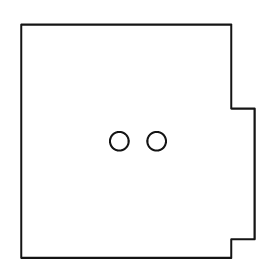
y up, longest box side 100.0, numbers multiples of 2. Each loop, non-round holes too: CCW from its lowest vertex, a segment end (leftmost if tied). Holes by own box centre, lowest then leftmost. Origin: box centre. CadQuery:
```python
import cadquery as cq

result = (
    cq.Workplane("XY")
    .moveTo(-50.0, -50.0)
    .lineTo(40.0, -50.0)
    .lineTo(40.0, -42.0)
    .lineTo(50.0, -42.0)
    .lineTo(50.0, 14.0)
    .lineTo(40.0, 14.0)
    .lineTo(40.0, 50.0)
    .lineTo(-50.0, 50.0)
    .close()
    .moveTo(-8.0, 0.0)
    .circle(4.0)
    .moveTo(8.0, 0.0)
    .circle(4.0)
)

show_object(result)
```